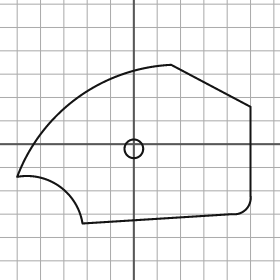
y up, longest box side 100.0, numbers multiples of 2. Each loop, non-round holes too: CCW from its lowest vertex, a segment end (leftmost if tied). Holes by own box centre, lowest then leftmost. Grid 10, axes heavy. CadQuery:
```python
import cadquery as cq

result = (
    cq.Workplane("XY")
    .moveTo(-22.0, -34.0)
    .lineTo(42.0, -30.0)
    .threePointArc((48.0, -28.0), (50.0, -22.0))
    .lineTo(50.0, 16.0)
    .lineTo(16.0, 34.0)
    .threePointArc((-24.0, 20.0), (-50.0, -14.0))
    .threePointArc((-32.0, -18.0), (-22.0, -34.0))
    .close()
    .moveTo(0.0, -2.0)
    .circle(4.0)
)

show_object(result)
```